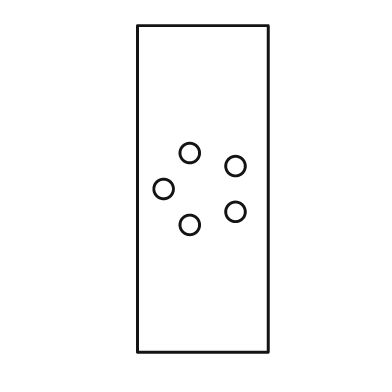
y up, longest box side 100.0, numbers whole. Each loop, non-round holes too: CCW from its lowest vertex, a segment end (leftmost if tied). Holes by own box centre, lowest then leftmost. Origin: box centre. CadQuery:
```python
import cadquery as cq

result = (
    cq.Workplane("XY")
    .moveTo(-20.0, -50.0)
    .lineTo(20.0, -50.0)
    .lineTo(20.0, 50.0)
    .lineTo(-20.0, 50.0)
    .close()
    .moveTo(-4.0, -11.0)
    .circle(3.0)
    .moveTo(10.0, -7.0)
    .circle(3.0)
    .moveTo(-12.0, 0.0)
    .circle(3.0)
    .moveTo(10.0, 7.0)
    .circle(3.0)
    .moveTo(-4.0, 11.0)
    .circle(3.0)
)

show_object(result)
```